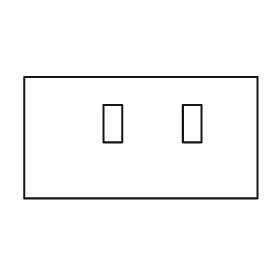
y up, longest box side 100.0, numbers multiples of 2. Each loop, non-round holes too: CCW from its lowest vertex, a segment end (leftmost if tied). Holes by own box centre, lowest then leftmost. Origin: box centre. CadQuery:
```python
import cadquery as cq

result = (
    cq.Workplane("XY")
    .moveTo(-50.0, -26.0)
    .lineTo(50.0, -26.0)
    .lineTo(50.0, 26.0)
    .lineTo(-50.0, 26.0)
    .close()
    .moveTo(-16.0, -2.0)
    .lineTo(-8.0, -2.0)
    .lineTo(-8.0, 14.0)
    .lineTo(-16.0, 14.0)
    .close()
    .moveTo(18.0, -2.0)
    .lineTo(26.0, -2.0)
    .lineTo(26.0, 14.0)
    .lineTo(18.0, 14.0)
    .close()
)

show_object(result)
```